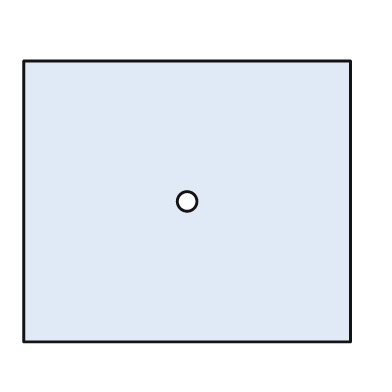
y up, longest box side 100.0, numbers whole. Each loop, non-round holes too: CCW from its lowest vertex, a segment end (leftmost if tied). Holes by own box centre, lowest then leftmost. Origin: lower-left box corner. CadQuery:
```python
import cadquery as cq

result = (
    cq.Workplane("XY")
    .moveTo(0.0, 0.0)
    .lineTo(100.0, 0.0)
    .lineTo(100.0, 86.0)
    .lineTo(0.0, 86.0)
    .close()
    .moveTo(50.0, 43.0)
    .circle(3.0)
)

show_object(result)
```